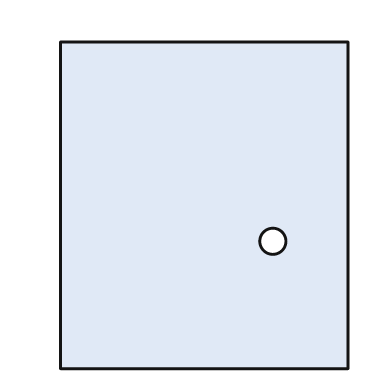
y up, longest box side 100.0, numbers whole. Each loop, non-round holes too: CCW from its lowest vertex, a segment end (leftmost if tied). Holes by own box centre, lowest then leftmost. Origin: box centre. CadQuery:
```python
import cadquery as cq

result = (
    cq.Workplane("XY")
    .moveTo(-44.0, -50.0)
    .lineTo(44.0, -50.0)
    .lineTo(44.0, 50.0)
    .lineTo(-44.0, 50.0)
    .close()
    .moveTo(21.0, -11.0)
    .circle(4.0)
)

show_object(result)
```